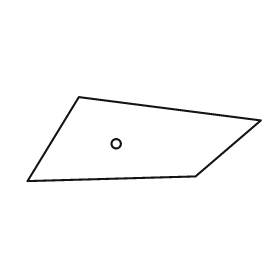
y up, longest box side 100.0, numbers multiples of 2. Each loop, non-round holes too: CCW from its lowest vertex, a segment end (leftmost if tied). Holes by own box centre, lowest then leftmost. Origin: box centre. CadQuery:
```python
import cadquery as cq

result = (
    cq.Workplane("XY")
    .moveTo(-50.0, -18.0)
    .lineTo(22.0, -16.0)
    .lineTo(50.0, 8.0)
    .lineTo(-28.0, 18.0)
    .close()
    .moveTo(-12.0, -2.0)
    .circle(2.0)
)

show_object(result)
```